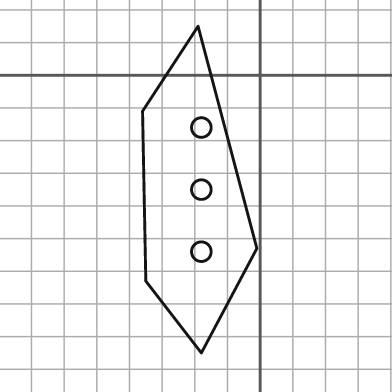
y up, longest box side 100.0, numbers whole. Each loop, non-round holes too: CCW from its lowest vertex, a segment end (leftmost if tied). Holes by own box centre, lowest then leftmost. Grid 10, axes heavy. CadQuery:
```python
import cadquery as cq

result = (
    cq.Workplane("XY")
    .moveTo(-18.0, -85.0)
    .lineTo(-1.0, -53.0)
    .lineTo(-19.0, 15.0)
    .lineTo(-36.0, -11.0)
    .lineTo(-35.0, -63.0)
    .close()
    .moveTo(-18.0, -54.0)
    .circle(3.0)
    .moveTo(-18.0, -35.0)
    .circle(3.0)
    .moveTo(-18.0, -16.0)
    .circle(3.0)
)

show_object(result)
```